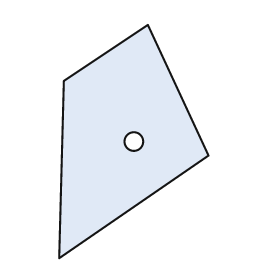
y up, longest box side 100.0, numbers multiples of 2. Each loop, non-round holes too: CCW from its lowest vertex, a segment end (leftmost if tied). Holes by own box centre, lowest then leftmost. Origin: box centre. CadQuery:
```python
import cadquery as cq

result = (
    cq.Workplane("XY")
    .moveTo(-32.0, -50.0)
    .lineTo(32.0, -6.0)
    .lineTo(6.0, 50.0)
    .lineTo(-30.0, 26.0)
    .close()
    .moveTo(0.0, 0.0)
    .circle(4.0)
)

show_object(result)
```